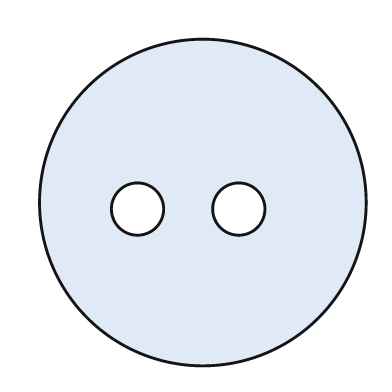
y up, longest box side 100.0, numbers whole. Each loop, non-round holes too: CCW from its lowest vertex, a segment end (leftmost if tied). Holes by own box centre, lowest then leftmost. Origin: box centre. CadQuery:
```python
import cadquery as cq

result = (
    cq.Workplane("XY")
    .moveTo(0.0, 0.0)
    .circle(50.0)
    .moveTo(-20.0, -2.0)
    .circle(8.0)
    .moveTo(11.0, -2.0)
    .circle(8.0)
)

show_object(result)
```